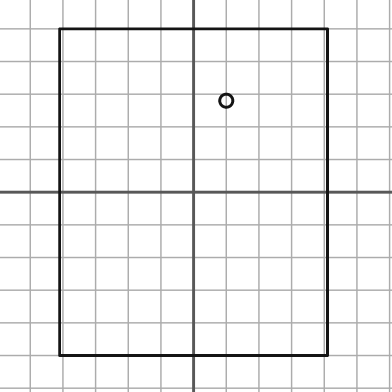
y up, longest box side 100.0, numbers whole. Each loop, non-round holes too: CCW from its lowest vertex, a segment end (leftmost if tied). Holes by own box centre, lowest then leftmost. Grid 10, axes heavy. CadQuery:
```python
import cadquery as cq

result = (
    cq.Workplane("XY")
    .moveTo(-41.0, -50.0)
    .lineTo(41.0, -50.0)
    .lineTo(41.0, 50.0)
    .lineTo(-41.0, 50.0)
    .close()
    .moveTo(10.0, 28.0)
    .circle(2.0)
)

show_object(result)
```